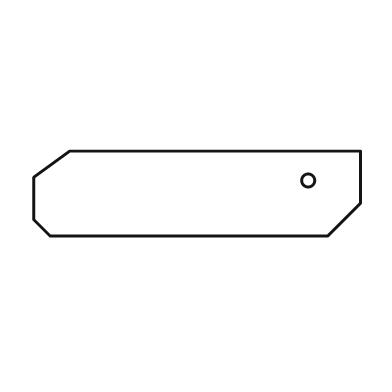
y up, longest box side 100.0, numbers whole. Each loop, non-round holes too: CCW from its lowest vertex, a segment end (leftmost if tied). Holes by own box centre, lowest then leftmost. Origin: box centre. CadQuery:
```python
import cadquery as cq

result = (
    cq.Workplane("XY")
    .moveTo(-45.0, -13.0)
    .lineTo(40.0, -13.0)
    .lineTo(50.0, -3.0)
    .lineTo(50.0, 13.0)
    .lineTo(-39.0, 13.0)
    .lineTo(-50.0, 5.0)
    .lineTo(-50.0, -8.0)
    .close()
    .moveTo(34.0, 4.0)
    .circle(2.0)
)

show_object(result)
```